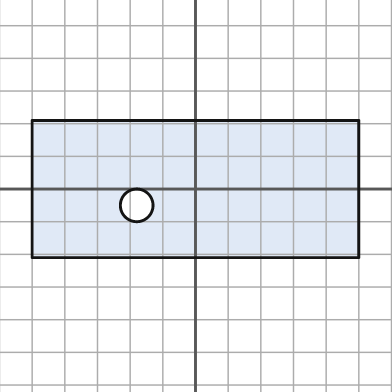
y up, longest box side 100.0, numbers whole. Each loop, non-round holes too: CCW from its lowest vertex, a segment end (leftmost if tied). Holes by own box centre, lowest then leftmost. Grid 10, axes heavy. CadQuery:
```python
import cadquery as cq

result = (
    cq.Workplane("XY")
    .moveTo(-50.0, -21.0)
    .lineTo(50.0, -21.0)
    .lineTo(50.0, 21.0)
    .lineTo(-50.0, 21.0)
    .close()
    .moveTo(-18.0, -5.0)
    .circle(5.0)
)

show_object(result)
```